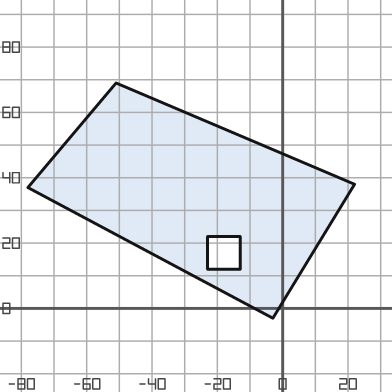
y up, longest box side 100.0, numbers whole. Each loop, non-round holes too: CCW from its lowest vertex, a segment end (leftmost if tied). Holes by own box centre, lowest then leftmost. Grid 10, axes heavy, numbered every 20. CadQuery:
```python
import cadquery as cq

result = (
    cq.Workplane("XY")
    .moveTo(-3.0, -3.0)
    .lineTo(22.0, 38.0)
    .lineTo(-51.0, 69.0)
    .lineTo(-78.0, 37.0)
    .close()
    .moveTo(-23.0, 12.0)
    .lineTo(-13.0, 12.0)
    .lineTo(-13.0, 22.0)
    .lineTo(-23.0, 22.0)
    .close()
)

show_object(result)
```